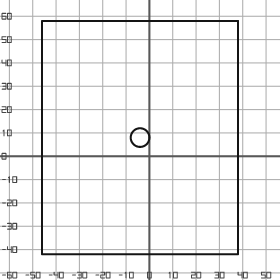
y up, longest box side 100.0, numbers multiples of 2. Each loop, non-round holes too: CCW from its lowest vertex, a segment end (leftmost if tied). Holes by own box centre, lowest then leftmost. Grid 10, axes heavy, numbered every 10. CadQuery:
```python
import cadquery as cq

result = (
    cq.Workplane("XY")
    .moveTo(-46.0, -42.0)
    .lineTo(38.0, -42.0)
    .lineTo(38.0, 58.0)
    .lineTo(-46.0, 58.0)
    .close()
    .moveTo(-4.0, 8.0)
    .circle(4.0)
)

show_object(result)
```